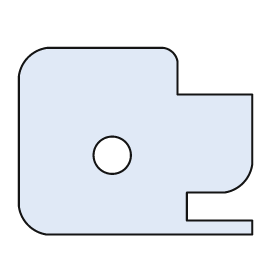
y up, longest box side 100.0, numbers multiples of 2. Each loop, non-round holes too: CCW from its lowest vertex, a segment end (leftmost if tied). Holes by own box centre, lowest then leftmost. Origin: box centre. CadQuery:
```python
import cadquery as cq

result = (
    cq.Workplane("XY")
    .moveTo(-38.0, -40.0)
    .lineTo(50.0, -40.0)
    .lineTo(50.0, -34.0)
    .lineTo(22.0, -34.0)
    .lineTo(22.0, -22.0)
    .lineTo(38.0, -22.0)
    .threePointArc((46.0, -18.0), (50.0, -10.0))
    .lineTo(50.0, 20.0)
    .lineTo(18.0, 20.0)
    .lineTo(18.0, 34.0)
    .threePointArc((16.0, 38.0), (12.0, 40.0))
    .lineTo(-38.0, 40.0)
    .threePointArc((-46.0, 36.0), (-50.0, 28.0))
    .lineTo(-50.0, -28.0)
    .threePointArc((-46.0, -36.0), (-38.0, -40.0))
    .close()
    .moveTo(-10.0, -6.0)
    .circle(8.0)
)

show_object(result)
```